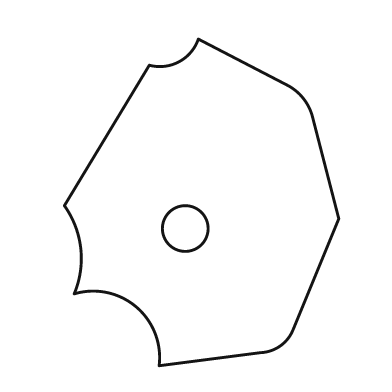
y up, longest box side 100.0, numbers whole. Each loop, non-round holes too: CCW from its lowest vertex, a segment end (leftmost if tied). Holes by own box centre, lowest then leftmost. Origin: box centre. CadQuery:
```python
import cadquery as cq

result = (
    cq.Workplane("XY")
    .moveTo(-13.0, -50.0)
    .lineTo(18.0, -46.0)
    .threePointArc((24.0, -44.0), (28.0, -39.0))
    .lineTo(42.0, -5.0)
    .lineTo(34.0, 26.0)
    .threePointArc((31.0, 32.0), (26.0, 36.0))
    .lineTo(-1.0, 50.0)
    .threePointArc((-7.0, 43.0), (-16.0, 42.0))
    .lineTo(-42.0, -1.0)
    .threePointArc((-37.0, -14.0), (-39.0, -28.0))
    .threePointArc((-20.0, -32.0), (-13.0, -50.0))
    .close()
    .moveTo(-5.0, -8.0)
    .circle(7.0)
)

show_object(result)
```